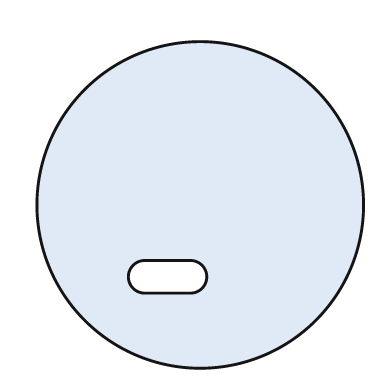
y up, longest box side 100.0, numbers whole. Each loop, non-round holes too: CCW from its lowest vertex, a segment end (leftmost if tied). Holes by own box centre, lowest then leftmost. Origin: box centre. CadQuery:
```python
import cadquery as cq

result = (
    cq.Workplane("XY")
    .moveTo(0.0, 0.0)
    .circle(50.0)
    .moveTo(-17.0, -27.0)
    .lineTo(-3.0, -27.0)
    .threePointArc((2.0, -22.0), (-3.0, -17.0))
    .lineTo(-17.0, -17.0)
    .threePointArc((-22.0, -22.0), (-17.0, -27.0))
    .close()
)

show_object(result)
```